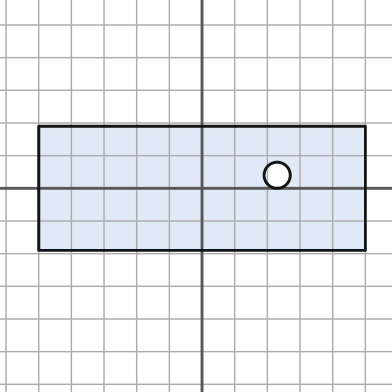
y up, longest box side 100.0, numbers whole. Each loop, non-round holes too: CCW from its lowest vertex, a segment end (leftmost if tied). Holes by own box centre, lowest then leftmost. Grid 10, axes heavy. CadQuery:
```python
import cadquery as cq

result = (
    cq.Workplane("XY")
    .moveTo(-50.0, -19.0)
    .lineTo(50.0, -19.0)
    .lineTo(50.0, 19.0)
    .lineTo(-50.0, 19.0)
    .close()
    .moveTo(23.0, 4.0)
    .circle(4.0)
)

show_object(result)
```